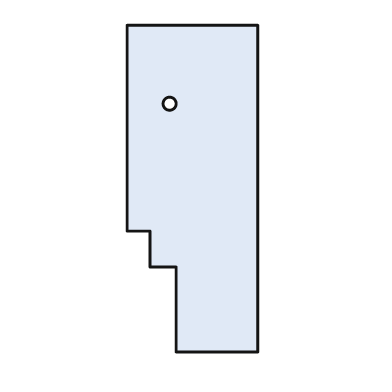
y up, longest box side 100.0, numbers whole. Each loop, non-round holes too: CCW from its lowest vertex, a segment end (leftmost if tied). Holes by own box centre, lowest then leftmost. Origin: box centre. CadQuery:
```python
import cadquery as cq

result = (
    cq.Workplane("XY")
    .moveTo(-5.0, -50.0)
    .lineTo(20.0, -50.0)
    .lineTo(20.0, 50.0)
    .lineTo(-20.0, 50.0)
    .lineTo(-20.0, -13.0)
    .lineTo(-13.0, -13.0)
    .lineTo(-13.0, -24.0)
    .lineTo(-5.0, -24.0)
    .close()
    .moveTo(-7.0, 26.0)
    .circle(2.0)
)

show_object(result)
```